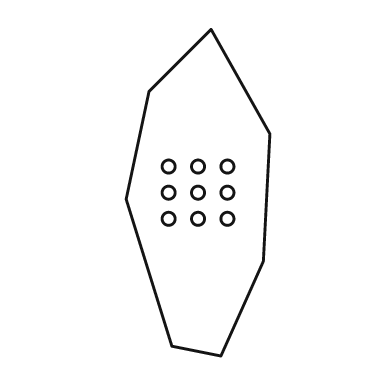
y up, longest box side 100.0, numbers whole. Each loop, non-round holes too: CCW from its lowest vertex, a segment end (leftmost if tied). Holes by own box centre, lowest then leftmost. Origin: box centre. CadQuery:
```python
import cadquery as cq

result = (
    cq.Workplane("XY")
    .moveTo(7.0, -50.0)
    .lineTo(20.0, -21.0)
    .lineTo(22.0, 18.0)
    .lineTo(4.0, 50.0)
    .lineTo(-15.0, 31.0)
    .lineTo(-22.0, -2.0)
    .lineTo(-8.0, -47.0)
    .close()
    .moveTo(-9.0, -8.0)
    .circle(2.0)
    .moveTo(0.0, -8.0)
    .circle(2.0)
    .moveTo(9.0, -8.0)
    .circle(2.0)
    .moveTo(-9.0, 0.0)
    .circle(2.0)
    .moveTo(0.0, 0.0)
    .circle(2.0)
    .moveTo(9.0, 0.0)
    .circle(2.0)
    .moveTo(-9.0, 8.0)
    .circle(2.0)
    .moveTo(0.0, 8.0)
    .circle(2.0)
    .moveTo(9.0, 8.0)
    .circle(2.0)
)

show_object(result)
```